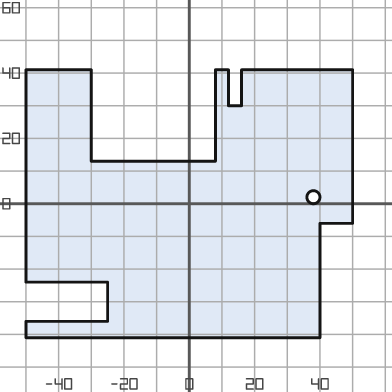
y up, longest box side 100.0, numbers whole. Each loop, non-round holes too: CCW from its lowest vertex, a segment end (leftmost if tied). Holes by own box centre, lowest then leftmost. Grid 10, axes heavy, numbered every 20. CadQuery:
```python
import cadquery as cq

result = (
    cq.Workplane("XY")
    .moveTo(-50.0, -41.0)
    .lineTo(40.0, -41.0)
    .lineTo(40.0, -6.0)
    .lineTo(50.0, -6.0)
    .lineTo(50.0, 41.0)
    .lineTo(16.0, 41.0)
    .lineTo(16.0, 30.0)
    .lineTo(12.0, 30.0)
    .lineTo(12.0, 41.0)
    .lineTo(8.0, 41.0)
    .lineTo(8.0, 13.0)
    .lineTo(-30.0, 13.0)
    .lineTo(-30.0, 41.0)
    .lineTo(-50.0, 41.0)
    .lineTo(-50.0, -24.0)
    .lineTo(-25.0, -24.0)
    .lineTo(-25.0, -36.0)
    .lineTo(-50.0, -36.0)
    .close()
    .moveTo(38.0, 2.0)
    .circle(2.0)
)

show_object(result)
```